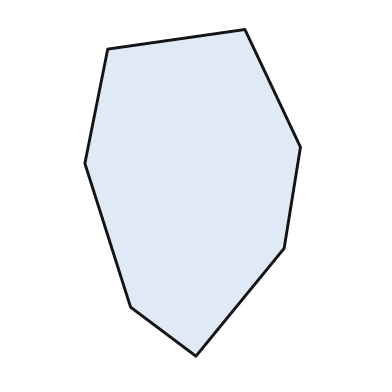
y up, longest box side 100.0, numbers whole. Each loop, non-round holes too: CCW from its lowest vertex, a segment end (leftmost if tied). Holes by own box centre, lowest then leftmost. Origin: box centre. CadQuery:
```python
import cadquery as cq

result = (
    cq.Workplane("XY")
    .moveTo(1.0, -50.0)
    .lineTo(28.0, -17.0)
    .lineTo(33.0, 14.0)
    .lineTo(16.0, 50.0)
    .lineTo(-26.0, 44.0)
    .lineTo(-33.0, 9.0)
    .lineTo(-19.0, -35.0)
    .close()
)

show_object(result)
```